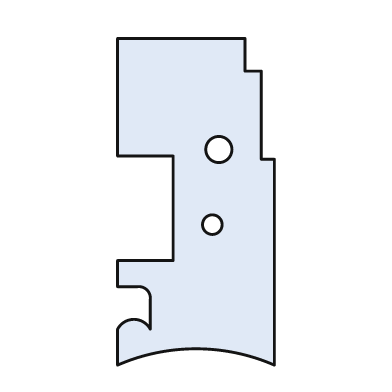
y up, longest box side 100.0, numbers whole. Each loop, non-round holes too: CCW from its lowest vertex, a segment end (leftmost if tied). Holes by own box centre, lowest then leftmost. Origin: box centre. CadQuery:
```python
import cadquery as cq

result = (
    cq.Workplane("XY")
    .moveTo(-24.0, -50.0)
    .threePointArc((0.0, -45.0), (24.0, -50.0))
    .lineTo(24.0, 13.0)
    .lineTo(20.0, 13.0)
    .lineTo(20.0, 40.0)
    .lineTo(15.0, 40.0)
    .lineTo(15.0, 50.0)
    .lineTo(-24.0, 50.0)
    .lineTo(-24.0, 14.0)
    .lineTo(-7.0, 14.0)
    .lineTo(-7.0, -18.0)
    .lineTo(-24.0, -18.0)
    .lineTo(-24.0, -26.0)
    .lineTo(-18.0, -26.0)
    .threePointArc((-15.0, -27.0), (-14.0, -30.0))
    .lineTo(-14.0, -39.0)
    .threePointArc((-19.0, -36.0), (-24.0, -39.0))
    .close()
    .moveTo(5.0, -7.0)
    .circle(3.0)
    .moveTo(7.0, 16.0)
    .circle(4.0)
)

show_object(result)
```